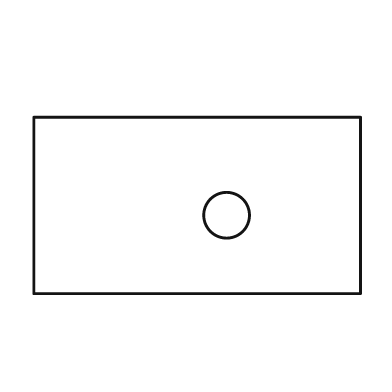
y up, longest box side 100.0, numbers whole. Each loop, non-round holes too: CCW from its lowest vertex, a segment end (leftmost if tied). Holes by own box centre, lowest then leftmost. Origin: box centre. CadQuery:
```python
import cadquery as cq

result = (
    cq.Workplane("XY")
    .moveTo(-50.0, -27.0)
    .lineTo(50.0, -27.0)
    .lineTo(50.0, 27.0)
    .lineTo(-50.0, 27.0)
    .close()
    .moveTo(9.0, -3.0)
    .circle(7.0)
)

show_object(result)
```